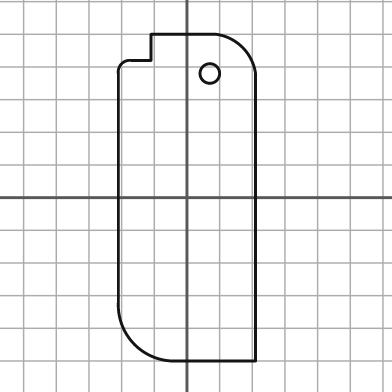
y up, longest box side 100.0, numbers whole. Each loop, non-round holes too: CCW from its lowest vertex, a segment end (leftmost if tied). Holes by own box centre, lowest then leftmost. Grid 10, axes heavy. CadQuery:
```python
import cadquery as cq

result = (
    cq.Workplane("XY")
    .moveTo(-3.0, -50.0)
    .lineTo(21.0, -50.0)
    .lineTo(21.0, 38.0)
    .threePointArc((17.0, 46.0), (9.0, 50.0))
    .lineTo(-11.0, 50.0)
    .lineTo(-11.0, 42.0)
    .lineTo(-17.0, 42.0)
    .threePointArc((-20.0, 41.0), (-21.0, 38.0))
    .lineTo(-21.0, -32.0)
    .threePointArc((-16.0, -45.0), (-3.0, -50.0))
    .close()
    .moveTo(7.0, 38.0)
    .circle(3.0)
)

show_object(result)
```